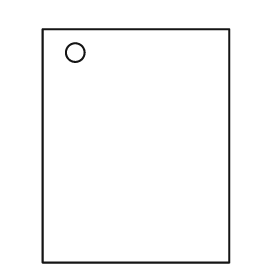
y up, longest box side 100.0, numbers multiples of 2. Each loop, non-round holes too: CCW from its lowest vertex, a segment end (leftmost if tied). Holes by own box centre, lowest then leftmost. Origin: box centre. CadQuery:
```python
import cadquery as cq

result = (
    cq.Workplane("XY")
    .moveTo(-40.0, -50.0)
    .lineTo(40.0, -50.0)
    .lineTo(40.0, 50.0)
    .lineTo(-40.0, 50.0)
    .close()
    .moveTo(-26.0, 40.0)
    .circle(4.0)
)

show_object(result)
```